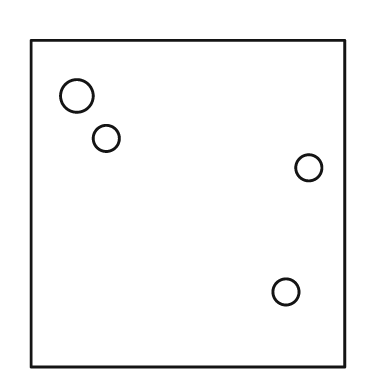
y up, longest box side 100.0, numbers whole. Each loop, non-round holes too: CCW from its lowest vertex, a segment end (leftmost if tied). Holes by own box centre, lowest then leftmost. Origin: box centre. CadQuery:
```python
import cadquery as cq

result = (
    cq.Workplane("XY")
    .moveTo(-48.0, -50.0)
    .lineTo(48.0, -50.0)
    .lineTo(48.0, 50.0)
    .lineTo(-48.0, 50.0)
    .close()
    .moveTo(30.0, -27.0)
    .circle(4.0)
    .moveTo(37.0, 11.0)
    .circle(4.0)
    .moveTo(-25.0, 20.0)
    .circle(4.0)
    .moveTo(-34.0, 33.0)
    .circle(5.0)
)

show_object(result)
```